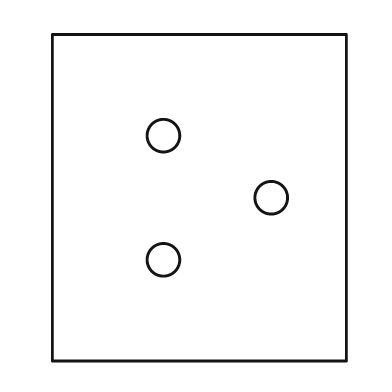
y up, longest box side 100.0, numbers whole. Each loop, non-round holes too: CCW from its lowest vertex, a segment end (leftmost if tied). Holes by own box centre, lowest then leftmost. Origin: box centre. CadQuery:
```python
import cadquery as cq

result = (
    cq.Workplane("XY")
    .moveTo(-45.0, -50.0)
    .lineTo(45.0, -50.0)
    .lineTo(45.0, 50.0)
    .lineTo(-45.0, 50.0)
    .close()
    .moveTo(-11.0, -19.0)
    .circle(5.0)
    .moveTo(22.0, 0.0)
    .circle(5.0)
    .moveTo(-11.0, 19.0)
    .circle(5.0)
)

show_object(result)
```